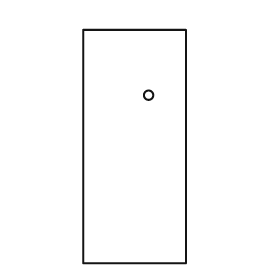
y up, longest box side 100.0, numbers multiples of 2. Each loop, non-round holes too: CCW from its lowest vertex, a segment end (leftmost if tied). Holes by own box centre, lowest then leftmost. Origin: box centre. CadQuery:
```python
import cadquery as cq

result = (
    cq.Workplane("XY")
    .moveTo(-22.0, -50.0)
    .lineTo(22.0, -50.0)
    .lineTo(22.0, 50.0)
    .lineTo(-22.0, 50.0)
    .close()
    .moveTo(6.0, 22.0)
    .circle(2.0)
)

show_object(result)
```